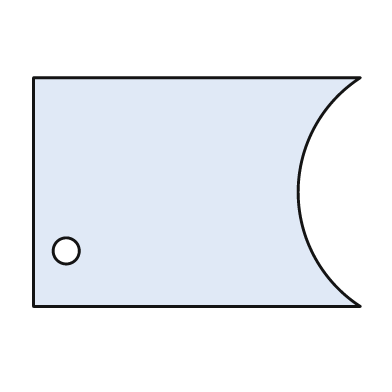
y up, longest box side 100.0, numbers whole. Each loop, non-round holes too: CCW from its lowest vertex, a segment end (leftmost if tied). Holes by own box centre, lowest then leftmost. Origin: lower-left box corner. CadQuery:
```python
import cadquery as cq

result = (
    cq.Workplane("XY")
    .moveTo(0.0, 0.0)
    .lineTo(100.0, 0.0)
    .threePointArc((81.0, 35.0), (100.0, 70.0))
    .lineTo(0.0, 70.0)
    .close()
    .moveTo(10.0, 17.0)
    .circle(4.0)
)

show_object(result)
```